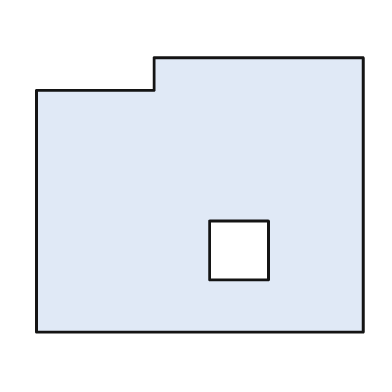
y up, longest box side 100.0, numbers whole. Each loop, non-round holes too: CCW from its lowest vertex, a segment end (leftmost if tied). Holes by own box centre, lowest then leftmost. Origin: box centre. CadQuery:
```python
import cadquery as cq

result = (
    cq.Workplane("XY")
    .moveTo(-50.0, -42.0)
    .lineTo(50.0, -42.0)
    .lineTo(50.0, 42.0)
    .lineTo(-14.0, 42.0)
    .lineTo(-14.0, 32.0)
    .lineTo(-50.0, 32.0)
    .close()
    .moveTo(3.0, -26.0)
    .lineTo(21.0, -26.0)
    .lineTo(21.0, -8.0)
    .lineTo(3.0, -8.0)
    .close()
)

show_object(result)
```